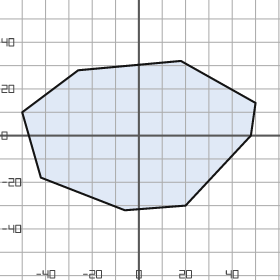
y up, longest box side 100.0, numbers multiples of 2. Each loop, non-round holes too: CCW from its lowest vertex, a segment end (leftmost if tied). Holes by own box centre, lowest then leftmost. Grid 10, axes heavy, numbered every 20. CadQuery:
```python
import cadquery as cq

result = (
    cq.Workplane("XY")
    .moveTo(-6.0, -32.0)
    .lineTo(20.0, -30.0)
    .lineTo(48.0, 0.0)
    .lineTo(50.0, 14.0)
    .lineTo(18.0, 32.0)
    .lineTo(-26.0, 28.0)
    .lineTo(-50.0, 10.0)
    .lineTo(-42.0, -18.0)
    .close()
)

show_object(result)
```